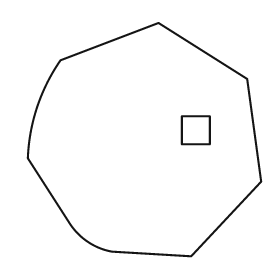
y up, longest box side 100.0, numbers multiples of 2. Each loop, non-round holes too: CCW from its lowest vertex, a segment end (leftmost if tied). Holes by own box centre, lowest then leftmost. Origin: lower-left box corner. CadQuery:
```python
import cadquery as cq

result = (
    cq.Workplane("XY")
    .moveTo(70.0, 0.0)
    .lineTo(100.0, 32.0)
    .lineTo(94.0, 76.0)
    .lineTo(56.0, 100.0)
    .lineTo(14.0, 84.0)
    .threePointArc((4.0, 64.0), (0.0, 42.0))
    .lineTo(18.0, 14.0)
    .threePointArc((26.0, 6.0), (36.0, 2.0))
    .close()
    .moveTo(66.0, 48.0)
    .lineTo(78.0, 48.0)
    .lineTo(78.0, 60.0)
    .lineTo(66.0, 60.0)
    .close()
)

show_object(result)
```